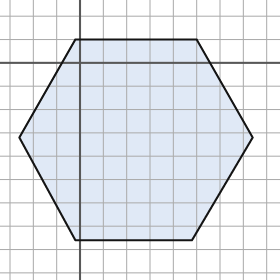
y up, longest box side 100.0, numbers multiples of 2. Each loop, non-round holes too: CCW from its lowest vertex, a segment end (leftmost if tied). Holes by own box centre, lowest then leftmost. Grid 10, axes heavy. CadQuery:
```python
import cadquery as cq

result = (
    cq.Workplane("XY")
    .moveTo(-2.0, -76.0)
    .lineTo(48.0, -76.0)
    .lineTo(74.0, -32.0)
    .lineTo(50.0, 10.0)
    .lineTo(-2.0, 10.0)
    .lineTo(-26.0, -32.0)
    .close()
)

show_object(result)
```